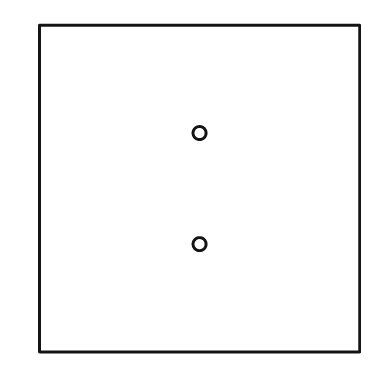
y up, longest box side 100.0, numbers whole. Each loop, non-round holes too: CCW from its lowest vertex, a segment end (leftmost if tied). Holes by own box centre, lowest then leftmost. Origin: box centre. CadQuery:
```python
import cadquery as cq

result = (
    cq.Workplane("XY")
    .moveTo(-49.0, -50.0)
    .lineTo(49.0, -50.0)
    .lineTo(49.0, 50.0)
    .lineTo(-49.0, 50.0)
    .close()
    .moveTo(0.0, -17.0)
    .circle(2.0)
    .moveTo(0.0, 17.0)
    .circle(2.0)
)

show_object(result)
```